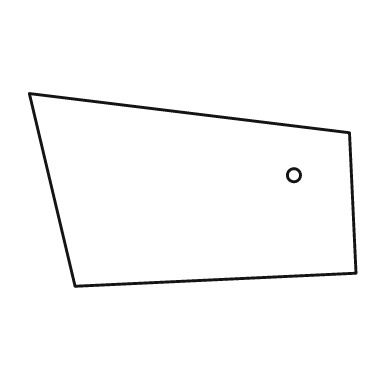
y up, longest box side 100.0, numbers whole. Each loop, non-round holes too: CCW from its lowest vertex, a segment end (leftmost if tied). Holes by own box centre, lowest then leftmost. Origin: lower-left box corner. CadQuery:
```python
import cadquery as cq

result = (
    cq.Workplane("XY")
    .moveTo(14.0, 0.0)
    .lineTo(100.0, 4.0)
    .lineTo(98.0, 47.0)
    .lineTo(0.0, 59.0)
    .close()
    .moveTo(81.0, 34.0)
    .circle(2.0)
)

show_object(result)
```